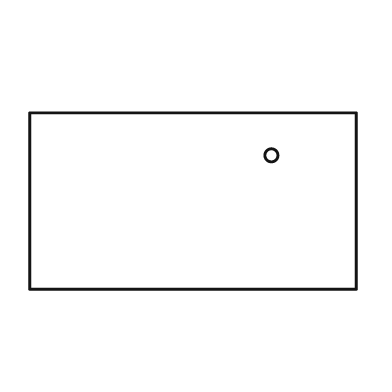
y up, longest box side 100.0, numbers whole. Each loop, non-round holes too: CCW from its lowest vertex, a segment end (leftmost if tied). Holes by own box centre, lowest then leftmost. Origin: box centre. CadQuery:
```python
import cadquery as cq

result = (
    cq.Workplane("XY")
    .moveTo(-50.0, -27.0)
    .lineTo(50.0, -27.0)
    .lineTo(50.0, 27.0)
    .lineTo(-50.0, 27.0)
    .close()
    .moveTo(24.0, 14.0)
    .circle(2.0)
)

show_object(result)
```